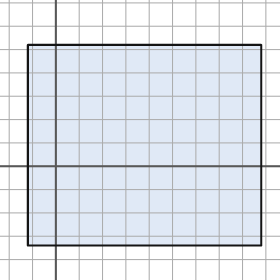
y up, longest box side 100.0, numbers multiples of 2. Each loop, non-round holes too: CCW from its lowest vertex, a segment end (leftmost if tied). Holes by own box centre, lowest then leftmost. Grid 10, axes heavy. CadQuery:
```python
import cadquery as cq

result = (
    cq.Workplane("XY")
    .moveTo(-12.0, -34.0)
    .lineTo(88.0, -34.0)
    .lineTo(88.0, 52.0)
    .lineTo(-12.0, 52.0)
    .close()
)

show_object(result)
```